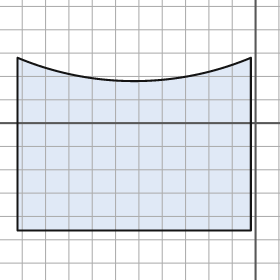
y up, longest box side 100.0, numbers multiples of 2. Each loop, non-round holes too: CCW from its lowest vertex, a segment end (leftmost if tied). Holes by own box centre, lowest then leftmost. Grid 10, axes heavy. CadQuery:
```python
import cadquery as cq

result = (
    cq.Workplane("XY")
    .moveTo(-102.0, -46.0)
    .lineTo(-2.0, -46.0)
    .lineTo(-2.0, 28.0)
    .threePointArc((-52.0, 18.0), (-102.0, 28.0))
    .close()
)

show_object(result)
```